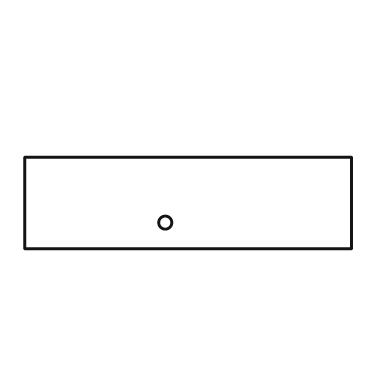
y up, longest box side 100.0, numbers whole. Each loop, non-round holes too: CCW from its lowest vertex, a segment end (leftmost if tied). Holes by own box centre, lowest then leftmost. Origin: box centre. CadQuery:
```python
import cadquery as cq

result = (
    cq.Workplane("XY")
    .moveTo(-50.0, -14.0)
    .lineTo(50.0, -14.0)
    .lineTo(50.0, 14.0)
    .lineTo(-50.0, 14.0)
    .close()
    .moveTo(-7.0, -6.0)
    .circle(2.0)
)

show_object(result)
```